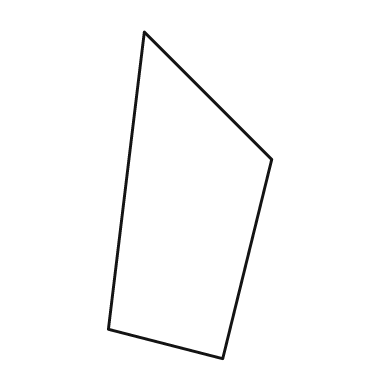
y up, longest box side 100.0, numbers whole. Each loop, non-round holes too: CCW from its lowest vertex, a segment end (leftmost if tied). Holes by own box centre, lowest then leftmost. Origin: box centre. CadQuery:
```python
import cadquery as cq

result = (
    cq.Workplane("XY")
    .moveTo(10.0, -50.0)
    .lineTo(25.0, 11.0)
    .lineTo(-14.0, 50.0)
    .lineTo(-25.0, -41.0)
    .close()
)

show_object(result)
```